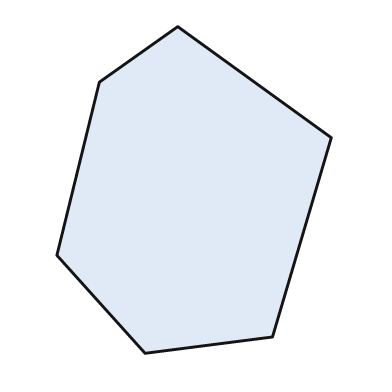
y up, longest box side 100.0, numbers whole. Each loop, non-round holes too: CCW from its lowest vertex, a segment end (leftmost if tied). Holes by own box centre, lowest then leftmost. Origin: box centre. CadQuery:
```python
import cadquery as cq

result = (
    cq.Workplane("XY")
    .moveTo(-15.0, -50.0)
    .lineTo(24.0, -45.0)
    .lineTo(42.0, 16.0)
    .lineTo(-5.0, 50.0)
    .lineTo(-29.0, 33.0)
    .lineTo(-42.0, -20.0)
    .close()
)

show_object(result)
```